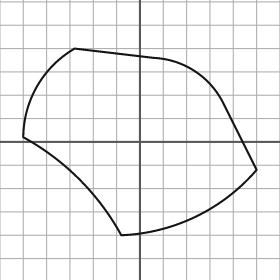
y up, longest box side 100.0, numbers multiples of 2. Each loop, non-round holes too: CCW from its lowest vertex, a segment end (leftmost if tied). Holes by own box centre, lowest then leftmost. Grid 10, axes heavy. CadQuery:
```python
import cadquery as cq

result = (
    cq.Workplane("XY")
    .moveTo(-8.0, -40.0)
    .threePointArc((24.0, -32.0), (50.0, -12.0))
    .lineTo(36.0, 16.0)
    .threePointArc((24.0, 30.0), (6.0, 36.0))
    .lineTo(-28.0, 40.0)
    .threePointArc((-44.0, 24.0), (-50.0, 2.0))
    .threePointArc((-26.0, -16.0), (-8.0, -40.0))
    .close()
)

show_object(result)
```